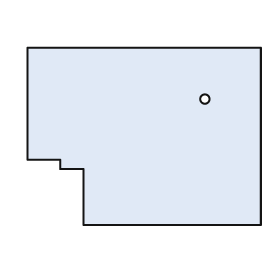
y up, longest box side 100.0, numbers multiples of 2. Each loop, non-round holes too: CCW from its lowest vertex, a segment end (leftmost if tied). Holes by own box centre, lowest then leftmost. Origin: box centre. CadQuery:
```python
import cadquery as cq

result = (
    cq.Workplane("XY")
    .moveTo(-26.0, -38.0)
    .lineTo(50.0, -38.0)
    .lineTo(50.0, 38.0)
    .lineTo(-50.0, 38.0)
    .lineTo(-50.0, -10.0)
    .lineTo(-36.0, -10.0)
    .lineTo(-36.0, -14.0)
    .lineTo(-26.0, -14.0)
    .close()
    .moveTo(26.0, 16.0)
    .circle(2.0)
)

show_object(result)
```